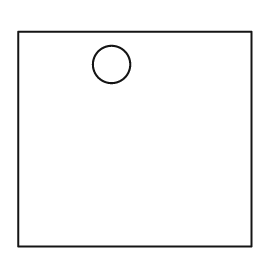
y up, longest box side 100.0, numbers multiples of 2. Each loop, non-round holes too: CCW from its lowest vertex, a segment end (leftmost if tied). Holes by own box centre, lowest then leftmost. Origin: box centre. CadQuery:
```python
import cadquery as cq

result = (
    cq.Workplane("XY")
    .moveTo(-50.0, -46.0)
    .lineTo(50.0, -46.0)
    .lineTo(50.0, 46.0)
    .lineTo(-50.0, 46.0)
    .close()
    .moveTo(-10.0, 32.0)
    .circle(8.0)
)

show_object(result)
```